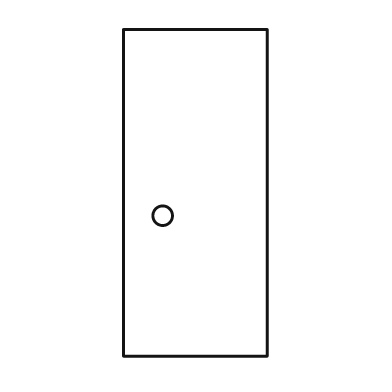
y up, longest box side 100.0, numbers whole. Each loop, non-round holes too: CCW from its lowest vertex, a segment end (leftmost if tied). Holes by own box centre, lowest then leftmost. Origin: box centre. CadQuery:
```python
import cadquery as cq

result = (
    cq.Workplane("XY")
    .moveTo(-22.0, -50.0)
    .lineTo(22.0, -50.0)
    .lineTo(22.0, 50.0)
    .lineTo(-22.0, 50.0)
    .close()
    .moveTo(-10.0, -7.0)
    .circle(3.0)
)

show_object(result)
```